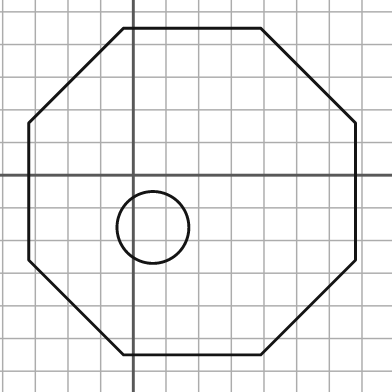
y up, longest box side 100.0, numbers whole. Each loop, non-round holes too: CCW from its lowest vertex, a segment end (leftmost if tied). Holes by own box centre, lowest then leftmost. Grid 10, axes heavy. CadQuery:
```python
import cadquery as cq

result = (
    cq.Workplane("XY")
    .moveTo(-3.0, -55.0)
    .lineTo(39.0, -55.0)
    .lineTo(68.0, -26.0)
    .lineTo(68.0, 16.0)
    .lineTo(39.0, 45.0)
    .lineTo(-3.0, 45.0)
    .lineTo(-32.0, 16.0)
    .lineTo(-32.0, -26.0)
    .close()
    .moveTo(6.0, -16.0)
    .circle(11.0)
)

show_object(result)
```